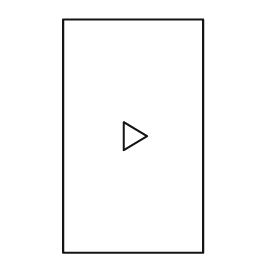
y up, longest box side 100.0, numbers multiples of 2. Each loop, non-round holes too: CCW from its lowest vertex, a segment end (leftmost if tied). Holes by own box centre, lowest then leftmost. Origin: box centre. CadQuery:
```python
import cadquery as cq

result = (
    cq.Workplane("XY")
    .moveTo(-30.0, -50.0)
    .lineTo(30.0, -50.0)
    .lineTo(30.0, 50.0)
    .lineTo(-30.0, 50.0)
    .close()
    .moveTo(-4.0, -6.0)
    .lineTo(6.0, 0.0)
    .lineTo(-4.0, 6.0)
    .close()
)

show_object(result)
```